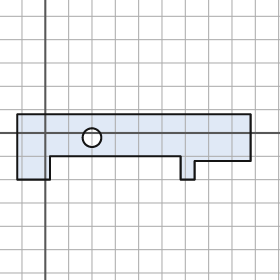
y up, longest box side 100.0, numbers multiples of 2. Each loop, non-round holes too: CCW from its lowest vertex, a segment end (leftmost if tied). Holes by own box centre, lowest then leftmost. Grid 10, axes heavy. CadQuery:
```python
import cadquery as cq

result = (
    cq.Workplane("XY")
    .moveTo(-12.0, -20.0)
    .lineTo(2.0, -20.0)
    .lineTo(2.0, -10.0)
    .lineTo(58.0, -10.0)
    .lineTo(58.0, -20.0)
    .lineTo(64.0, -20.0)
    .lineTo(64.0, -12.0)
    .lineTo(88.0, -12.0)
    .lineTo(88.0, 8.0)
    .lineTo(-12.0, 8.0)
    .close()
    .moveTo(20.0, -2.0)
    .circle(4.0)
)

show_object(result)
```